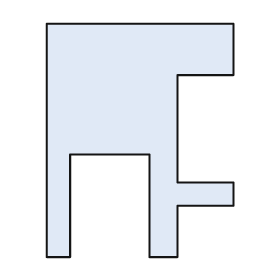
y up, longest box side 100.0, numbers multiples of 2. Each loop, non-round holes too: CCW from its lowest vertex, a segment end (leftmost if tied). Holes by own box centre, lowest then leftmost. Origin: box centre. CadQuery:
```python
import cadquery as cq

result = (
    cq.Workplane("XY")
    .moveTo(-40.0, -50.0)
    .lineTo(-30.0, -50.0)
    .lineTo(-30.0, -6.0)
    .lineTo(4.0, -6.0)
    .lineTo(4.0, -50.0)
    .lineTo(16.0, -50.0)
    .lineTo(16.0, -28.0)
    .lineTo(40.0, -28.0)
    .lineTo(40.0, -18.0)
    .lineTo(16.0, -18.0)
    .lineTo(16.0, 28.0)
    .lineTo(40.0, 28.0)
    .lineTo(40.0, 50.0)
    .lineTo(-40.0, 50.0)
    .close()
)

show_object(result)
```